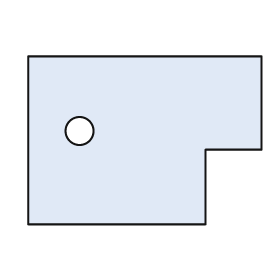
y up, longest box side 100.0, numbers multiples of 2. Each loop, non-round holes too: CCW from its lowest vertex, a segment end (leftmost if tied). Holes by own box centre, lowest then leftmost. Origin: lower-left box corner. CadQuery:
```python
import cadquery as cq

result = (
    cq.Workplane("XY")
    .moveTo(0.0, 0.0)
    .lineTo(76.0, 0.0)
    .lineTo(76.0, 32.0)
    .lineTo(100.0, 32.0)
    .lineTo(100.0, 72.0)
    .lineTo(0.0, 72.0)
    .close()
    .moveTo(22.0, 40.0)
    .circle(6.0)
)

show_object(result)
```